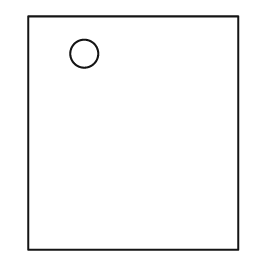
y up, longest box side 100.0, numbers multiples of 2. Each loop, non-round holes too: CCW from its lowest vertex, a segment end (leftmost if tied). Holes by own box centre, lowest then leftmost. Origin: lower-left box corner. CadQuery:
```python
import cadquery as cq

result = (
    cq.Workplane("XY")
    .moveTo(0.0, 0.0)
    .lineTo(90.0, 0.0)
    .lineTo(90.0, 100.0)
    .lineTo(0.0, 100.0)
    .close()
    .moveTo(24.0, 84.0)
    .circle(6.0)
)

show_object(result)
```